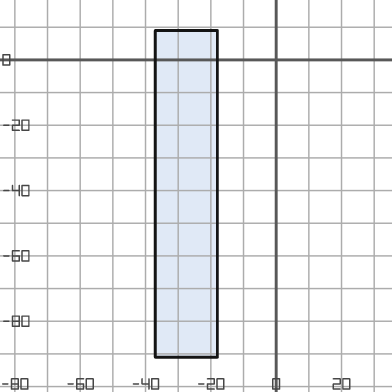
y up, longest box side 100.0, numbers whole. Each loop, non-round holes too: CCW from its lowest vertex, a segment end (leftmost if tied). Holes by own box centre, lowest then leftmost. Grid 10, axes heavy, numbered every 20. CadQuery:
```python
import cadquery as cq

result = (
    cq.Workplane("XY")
    .moveTo(-37.0, -91.0)
    .lineTo(-18.0, -91.0)
    .lineTo(-18.0, 9.0)
    .lineTo(-37.0, 9.0)
    .close()
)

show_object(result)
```